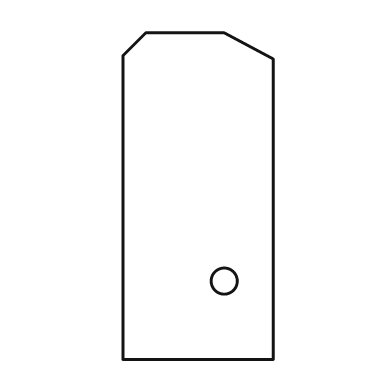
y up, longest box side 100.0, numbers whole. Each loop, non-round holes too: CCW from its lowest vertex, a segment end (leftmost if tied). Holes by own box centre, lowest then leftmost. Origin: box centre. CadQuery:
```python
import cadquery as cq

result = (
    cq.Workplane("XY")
    .moveTo(-23.0, -50.0)
    .lineTo(23.0, -50.0)
    .lineTo(23.0, 42.0)
    .lineTo(8.0, 50.0)
    .lineTo(-16.0, 50.0)
    .lineTo(-23.0, 43.0)
    .close()
    .moveTo(8.0, -26.0)
    .circle(4.0)
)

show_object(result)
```